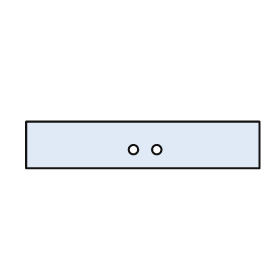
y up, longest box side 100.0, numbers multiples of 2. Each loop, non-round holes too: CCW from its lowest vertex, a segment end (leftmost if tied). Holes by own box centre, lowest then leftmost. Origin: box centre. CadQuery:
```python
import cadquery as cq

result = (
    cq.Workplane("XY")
    .moveTo(-50.0, -10.0)
    .lineTo(50.0, -10.0)
    .lineTo(50.0, 10.0)
    .lineTo(-50.0, 10.0)
    .close()
    .moveTo(-4.0, -2.0)
    .circle(2.0)
    .moveTo(6.0, -2.0)
    .circle(2.0)
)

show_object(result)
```